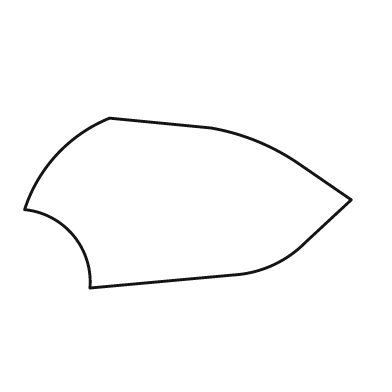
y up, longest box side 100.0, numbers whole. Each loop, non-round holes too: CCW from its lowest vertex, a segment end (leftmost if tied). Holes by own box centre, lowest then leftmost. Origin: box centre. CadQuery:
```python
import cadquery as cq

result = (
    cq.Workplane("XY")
    .moveTo(-30.0, -26.0)
    .lineTo(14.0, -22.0)
    .threePointArc((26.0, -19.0), (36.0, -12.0))
    .lineTo(50.0, 1.0)
    .lineTo(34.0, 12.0)
    .threePointArc((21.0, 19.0), (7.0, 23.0))
    .lineTo(-24.0, 26.0)
    .threePointArc((-40.0, 15.0), (-50.0, -2.0))
    .threePointArc((-35.0, -10.0), (-30.0, -26.0))
    .close()
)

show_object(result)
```